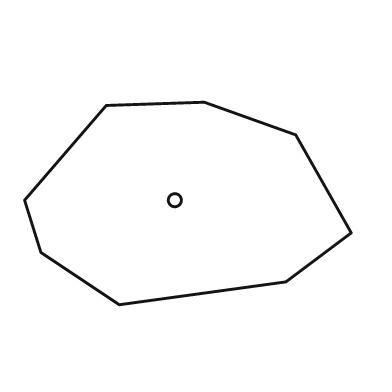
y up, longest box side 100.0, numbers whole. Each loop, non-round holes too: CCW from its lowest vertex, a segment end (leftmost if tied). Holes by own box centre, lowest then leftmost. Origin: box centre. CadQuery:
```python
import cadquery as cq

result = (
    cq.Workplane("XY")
    .moveTo(-21.0, -31.0)
    .lineTo(30.0, -24.0)
    .lineTo(50.0, -9.0)
    .lineTo(33.0, 21.0)
    .lineTo(5.0, 31.0)
    .lineTo(-25.0, 30.0)
    .lineTo(-50.0, 1.0)
    .lineTo(-45.0, -15.0)
    .close()
    .moveTo(-4.0, 1.0)
    .circle(2.0)
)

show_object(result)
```